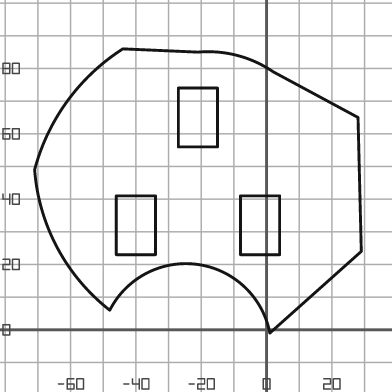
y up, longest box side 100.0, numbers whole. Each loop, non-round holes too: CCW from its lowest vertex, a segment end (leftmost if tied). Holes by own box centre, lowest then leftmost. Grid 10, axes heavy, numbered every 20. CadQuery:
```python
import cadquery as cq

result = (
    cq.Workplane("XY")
    .moveTo(1.0, -1.0)
    .lineTo(29.0, 24.0)
    .lineTo(28.0, 65.0)
    .lineTo(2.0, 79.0)
    .threePointArc((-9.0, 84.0), (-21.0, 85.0))
    .lineTo(-44.0, 86.0)
    .threePointArc((-61.0, 70.0), (-71.0, 49.0))
    .threePointArc((-64.0, 25.0), (-48.0, 6.0))
    .threePointArc((-21.0, 20.0), (1.0, -1.0))
    .close()
    .moveTo(-46.0, 23.0)
    .lineTo(-34.0, 23.0)
    .lineTo(-34.0, 41.0)
    .lineTo(-46.0, 41.0)
    .close()
    .moveTo(-8.0, 23.0)
    .lineTo(4.0, 23.0)
    .lineTo(4.0, 41.0)
    .lineTo(-8.0, 41.0)
    .close()
    .moveTo(-27.0, 56.0)
    .lineTo(-15.0, 56.0)
    .lineTo(-15.0, 74.0)
    .lineTo(-27.0, 74.0)
    .close()
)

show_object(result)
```